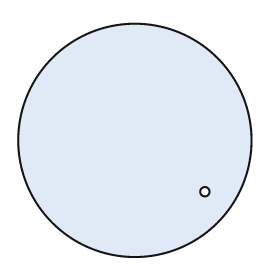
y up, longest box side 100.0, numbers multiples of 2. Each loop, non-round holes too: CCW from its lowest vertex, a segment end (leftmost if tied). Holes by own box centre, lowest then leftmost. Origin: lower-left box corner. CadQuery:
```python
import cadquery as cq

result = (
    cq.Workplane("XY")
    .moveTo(50.0, 50.0)
    .circle(50.0)
    .moveTo(80.0, 28.0)
    .circle(2.0)
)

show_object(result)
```